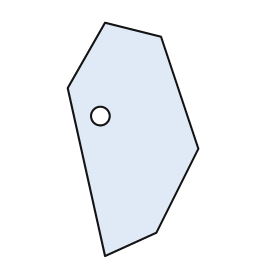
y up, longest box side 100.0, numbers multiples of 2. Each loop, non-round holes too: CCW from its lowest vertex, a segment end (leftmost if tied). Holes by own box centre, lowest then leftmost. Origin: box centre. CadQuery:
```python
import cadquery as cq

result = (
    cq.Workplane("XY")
    .moveTo(-12.0, -50.0)
    .lineTo(10.0, -40.0)
    .lineTo(28.0, -4.0)
    .lineTo(12.0, 44.0)
    .lineTo(-12.0, 50.0)
    .lineTo(-28.0, 22.0)
    .close()
    .moveTo(-14.0, 10.0)
    .circle(4.0)
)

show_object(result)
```